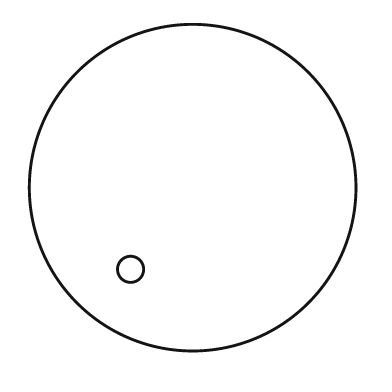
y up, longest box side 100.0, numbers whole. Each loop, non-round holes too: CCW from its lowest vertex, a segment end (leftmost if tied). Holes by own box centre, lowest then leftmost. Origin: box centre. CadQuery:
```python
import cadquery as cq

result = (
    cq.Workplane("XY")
    .moveTo(0.0, 0.0)
    .circle(50.0)
    .moveTo(-19.0, -25.0)
    .circle(4.0)
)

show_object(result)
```